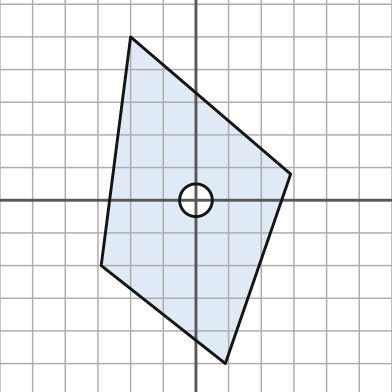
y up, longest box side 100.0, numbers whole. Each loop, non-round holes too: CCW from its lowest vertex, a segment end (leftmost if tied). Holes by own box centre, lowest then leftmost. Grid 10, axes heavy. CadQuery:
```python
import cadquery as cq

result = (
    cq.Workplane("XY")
    .moveTo(9.0, -50.0)
    .lineTo(29.0, 8.0)
    .lineTo(-20.0, 50.0)
    .lineTo(-29.0, -20.0)
    .close()
    .moveTo(0.0, 0.0)
    .circle(5.0)
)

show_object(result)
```